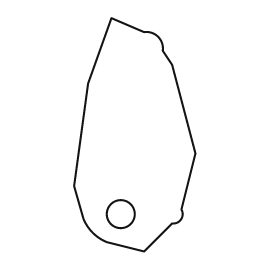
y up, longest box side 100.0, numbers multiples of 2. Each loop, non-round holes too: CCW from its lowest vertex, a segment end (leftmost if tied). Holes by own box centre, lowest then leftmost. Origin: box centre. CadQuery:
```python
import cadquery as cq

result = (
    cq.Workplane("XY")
    .moveTo(4.0, -50.0)
    .lineTo(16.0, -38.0)
    .threePointArc((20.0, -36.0), (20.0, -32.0))
    .lineTo(26.0, -8.0)
    .lineTo(16.0, 30.0)
    .lineTo(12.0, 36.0)
    .threePointArc((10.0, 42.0), (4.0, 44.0))
    .lineTo(-10.0, 50.0)
    .lineTo(-20.0, 22.0)
    .lineTo(-26.0, -22.0)
    .lineTo(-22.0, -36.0)
    .threePointArc((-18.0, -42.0), (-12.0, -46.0))
    .close()
    .moveTo(-6.0, -34.0)
    .circle(6.0)
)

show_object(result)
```